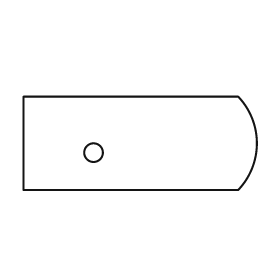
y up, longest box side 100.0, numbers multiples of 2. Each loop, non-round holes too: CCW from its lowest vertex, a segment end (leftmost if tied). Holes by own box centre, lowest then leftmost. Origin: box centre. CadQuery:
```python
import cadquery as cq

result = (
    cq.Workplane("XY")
    .moveTo(-50.0, -20.0)
    .lineTo(42.0, -20.0)
    .threePointArc((50.0, 0.0), (42.0, 20.0))
    .lineTo(-50.0, 20.0)
    .close()
    .moveTo(-20.0, -4.0)
    .circle(4.0)
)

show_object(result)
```